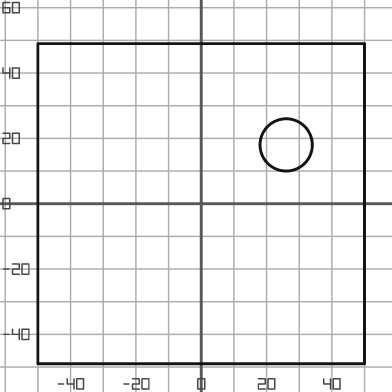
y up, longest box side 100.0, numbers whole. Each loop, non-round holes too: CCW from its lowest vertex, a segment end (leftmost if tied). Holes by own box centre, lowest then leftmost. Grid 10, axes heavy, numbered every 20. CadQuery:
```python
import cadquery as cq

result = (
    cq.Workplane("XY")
    .moveTo(-50.0, -49.0)
    .lineTo(50.0, -49.0)
    .lineTo(50.0, 49.0)
    .lineTo(-50.0, 49.0)
    .close()
    .moveTo(26.0, 18.0)
    .circle(8.0)
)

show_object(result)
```